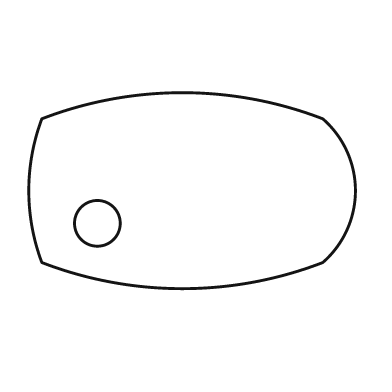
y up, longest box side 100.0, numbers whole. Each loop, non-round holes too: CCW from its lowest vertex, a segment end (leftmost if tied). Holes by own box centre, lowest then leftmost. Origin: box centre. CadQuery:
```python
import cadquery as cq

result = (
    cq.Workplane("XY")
    .moveTo(-46.0, -22.0)
    .threePointArc((-3.0, -30.0), (40.0, -22.0))
    .threePointArc((50.0, 0.0), (40.0, 22.0))
    .threePointArc((-3.0, 30.0), (-46.0, 22.0))
    .threePointArc((-50.0, 0.0), (-46.0, -22.0))
    .close()
    .moveTo(-29.0, -10.0)
    .circle(7.0)
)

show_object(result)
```